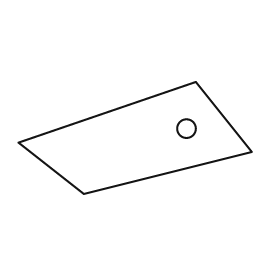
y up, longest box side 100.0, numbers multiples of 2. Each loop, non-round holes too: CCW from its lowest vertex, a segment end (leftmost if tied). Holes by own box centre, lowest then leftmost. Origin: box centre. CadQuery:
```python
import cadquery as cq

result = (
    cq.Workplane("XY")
    .moveTo(-22.0, -24.0)
    .lineTo(50.0, -6.0)
    .lineTo(26.0, 24.0)
    .lineTo(-50.0, -2.0)
    .close()
    .moveTo(22.0, 4.0)
    .circle(4.0)
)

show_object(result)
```